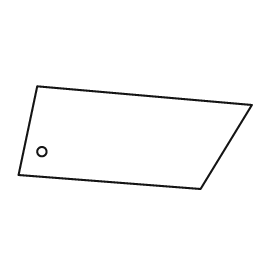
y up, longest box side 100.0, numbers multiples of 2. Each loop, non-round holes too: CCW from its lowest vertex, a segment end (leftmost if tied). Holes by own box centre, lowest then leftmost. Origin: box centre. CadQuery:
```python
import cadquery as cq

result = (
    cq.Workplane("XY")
    .moveTo(28.0, -22.0)
    .lineTo(50.0, 14.0)
    .lineTo(-42.0, 22.0)
    .lineTo(-50.0, -16.0)
    .close()
    .moveTo(-40.0, -6.0)
    .circle(2.0)
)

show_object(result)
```